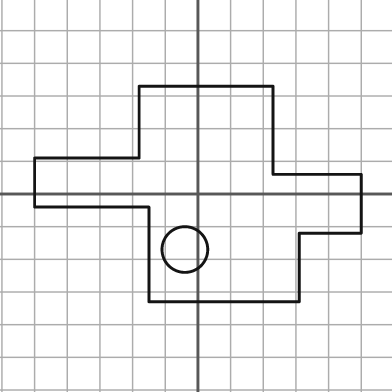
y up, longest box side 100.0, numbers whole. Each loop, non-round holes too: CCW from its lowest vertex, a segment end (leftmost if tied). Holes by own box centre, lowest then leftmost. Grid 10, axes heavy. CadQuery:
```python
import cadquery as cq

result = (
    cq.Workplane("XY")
    .moveTo(-15.0, -33.0)
    .lineTo(31.0, -33.0)
    .lineTo(31.0, -12.0)
    .lineTo(50.0, -12.0)
    .lineTo(50.0, 6.0)
    .lineTo(23.0, 6.0)
    .lineTo(23.0, 33.0)
    .lineTo(-18.0, 33.0)
    .lineTo(-18.0, 11.0)
    .lineTo(-50.0, 11.0)
    .lineTo(-50.0, -4.0)
    .lineTo(-15.0, -4.0)
    .close()
    .moveTo(-4.0, -17.0)
    .circle(7.0)
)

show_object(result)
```